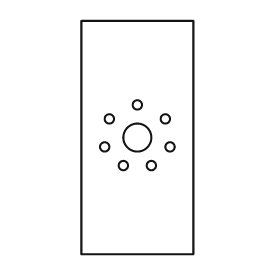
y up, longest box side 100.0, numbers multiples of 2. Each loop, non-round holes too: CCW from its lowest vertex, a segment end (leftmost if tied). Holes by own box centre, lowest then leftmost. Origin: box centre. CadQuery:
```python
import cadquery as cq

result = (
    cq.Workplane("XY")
    .moveTo(-24.0, -50.0)
    .lineTo(24.0, -50.0)
    .lineTo(24.0, 50.0)
    .lineTo(-24.0, 50.0)
    .close()
    .moveTo(-6.0, -12.0)
    .circle(2.0)
    .moveTo(6.0, -12.0)
    .circle(2.0)
    .moveTo(-14.0, -4.0)
    .circle(2.0)
    .moveTo(14.0, -4.0)
    .circle(2.0)
    .moveTo(0.0, 0.0)
    .circle(6.0)
    .moveTo(-12.0, 8.0)
    .circle(2.0)
    .moveTo(12.0, 8.0)
    .circle(2.0)
    .moveTo(0.0, 14.0)
    .circle(2.0)
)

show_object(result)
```